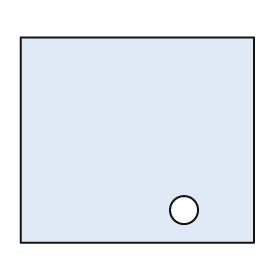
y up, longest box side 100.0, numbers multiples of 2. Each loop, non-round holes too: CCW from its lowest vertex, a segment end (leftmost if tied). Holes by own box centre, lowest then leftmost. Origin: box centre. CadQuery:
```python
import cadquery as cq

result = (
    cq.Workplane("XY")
    .moveTo(-50.0, -44.0)
    .lineTo(50.0, -44.0)
    .lineTo(50.0, 44.0)
    .lineTo(-50.0, 44.0)
    .close()
    .moveTo(20.0, -30.0)
    .circle(6.0)
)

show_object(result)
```